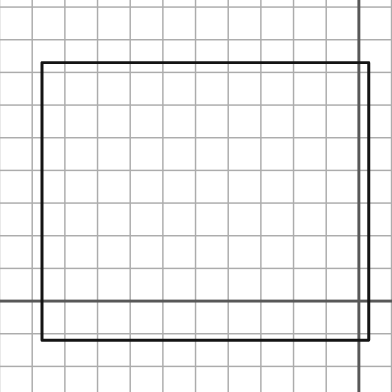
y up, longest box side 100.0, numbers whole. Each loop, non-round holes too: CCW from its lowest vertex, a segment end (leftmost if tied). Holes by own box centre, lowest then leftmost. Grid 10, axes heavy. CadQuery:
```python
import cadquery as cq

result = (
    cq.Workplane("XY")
    .moveTo(-97.0, -12.0)
    .lineTo(3.0, -12.0)
    .lineTo(3.0, 73.0)
    .lineTo(-97.0, 73.0)
    .close()
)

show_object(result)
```